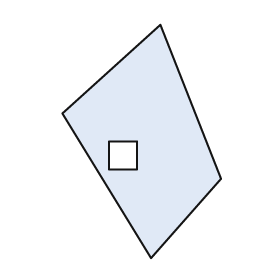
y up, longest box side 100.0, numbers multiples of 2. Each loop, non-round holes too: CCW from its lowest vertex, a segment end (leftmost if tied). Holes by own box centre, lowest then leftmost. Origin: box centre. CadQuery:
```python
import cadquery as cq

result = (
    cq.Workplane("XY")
    .moveTo(4.0, -50.0)
    .lineTo(34.0, -16.0)
    .lineTo(8.0, 50.0)
    .lineTo(-34.0, 12.0)
    .close()
    .moveTo(-14.0, -12.0)
    .lineTo(-2.0, -12.0)
    .lineTo(-2.0, 0.0)
    .lineTo(-14.0, 0.0)
    .close()
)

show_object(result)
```